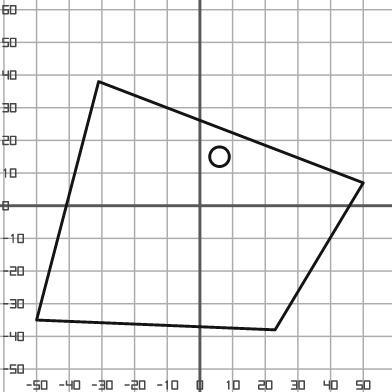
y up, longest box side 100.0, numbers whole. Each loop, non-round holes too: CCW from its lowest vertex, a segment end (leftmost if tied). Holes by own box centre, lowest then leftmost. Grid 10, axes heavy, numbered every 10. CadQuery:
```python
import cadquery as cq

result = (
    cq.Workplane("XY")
    .moveTo(23.0, -38.0)
    .lineTo(50.0, 7.0)
    .lineTo(-31.0, 38.0)
    .lineTo(-50.0, -35.0)
    .close()
    .moveTo(6.0, 15.0)
    .circle(3.0)
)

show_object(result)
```